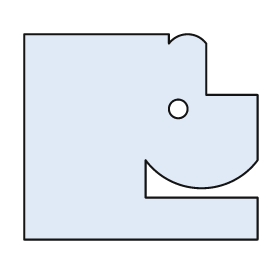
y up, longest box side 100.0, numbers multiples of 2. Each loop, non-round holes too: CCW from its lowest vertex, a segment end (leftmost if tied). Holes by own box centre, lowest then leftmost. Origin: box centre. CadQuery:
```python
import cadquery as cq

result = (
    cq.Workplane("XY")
    .moveTo(-50.0, -44.0)
    .lineTo(50.0, -44.0)
    .lineTo(50.0, -26.0)
    .lineTo(2.0, -26.0)
    .lineTo(2.0, -10.0)
    .threePointArc((26.0, -22.0), (50.0, -10.0))
    .lineTo(50.0, 18.0)
    .lineTo(28.0, 18.0)
    .lineTo(28.0, 40.0)
    .threePointArc((20.0, 44.0), (12.0, 40.0))
    .lineTo(12.0, 44.0)
    .lineTo(-50.0, 44.0)
    .close()
    .moveTo(16.0, 12.0)
    .circle(4.0)
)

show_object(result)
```